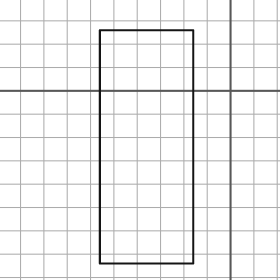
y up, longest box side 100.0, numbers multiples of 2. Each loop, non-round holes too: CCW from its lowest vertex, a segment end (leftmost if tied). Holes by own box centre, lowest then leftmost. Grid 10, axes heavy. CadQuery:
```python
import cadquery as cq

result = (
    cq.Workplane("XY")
    .moveTo(-56.0, -74.0)
    .lineTo(-16.0, -74.0)
    .lineTo(-16.0, 26.0)
    .lineTo(-56.0, 26.0)
    .close()
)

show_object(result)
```